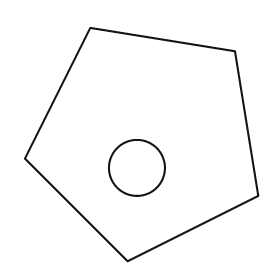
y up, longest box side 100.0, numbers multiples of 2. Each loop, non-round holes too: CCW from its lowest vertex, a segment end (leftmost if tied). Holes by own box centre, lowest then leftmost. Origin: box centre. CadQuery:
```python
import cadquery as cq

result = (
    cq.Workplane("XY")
    .moveTo(-6.0, -50.0)
    .lineTo(50.0, -22.0)
    .lineTo(40.0, 40.0)
    .lineTo(-22.0, 50.0)
    .lineTo(-50.0, -6.0)
    .close()
    .moveTo(-2.0, -10.0)
    .circle(12.0)
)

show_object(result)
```